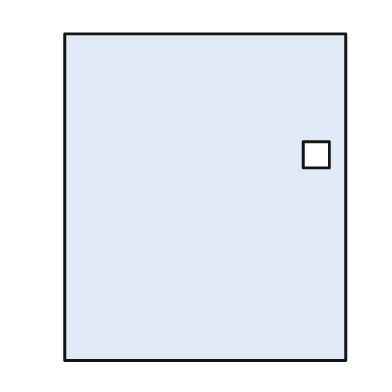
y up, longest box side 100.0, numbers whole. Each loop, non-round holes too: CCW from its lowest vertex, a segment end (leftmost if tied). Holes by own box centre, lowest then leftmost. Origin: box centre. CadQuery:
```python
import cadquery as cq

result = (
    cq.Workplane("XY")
    .moveTo(-43.0, -50.0)
    .lineTo(43.0, -50.0)
    .lineTo(43.0, 50.0)
    .lineTo(-43.0, 50.0)
    .close()
    .moveTo(30.0, 9.0)
    .lineTo(38.0, 9.0)
    .lineTo(38.0, 17.0)
    .lineTo(30.0, 17.0)
    .close()
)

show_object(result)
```